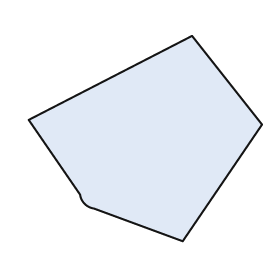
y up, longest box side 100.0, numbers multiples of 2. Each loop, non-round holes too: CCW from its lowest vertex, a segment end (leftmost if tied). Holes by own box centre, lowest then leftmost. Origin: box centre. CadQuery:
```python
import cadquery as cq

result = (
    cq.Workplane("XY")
    .moveTo(16.0, -44.0)
    .lineTo(50.0, 6.0)
    .lineTo(20.0, 44.0)
    .lineTo(-50.0, 8.0)
    .lineTo(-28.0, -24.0)
    .threePointArc((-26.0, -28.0), (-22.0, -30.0))
    .close()
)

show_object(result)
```